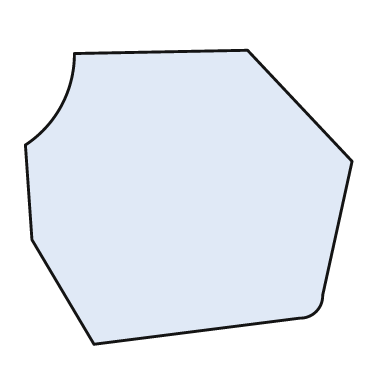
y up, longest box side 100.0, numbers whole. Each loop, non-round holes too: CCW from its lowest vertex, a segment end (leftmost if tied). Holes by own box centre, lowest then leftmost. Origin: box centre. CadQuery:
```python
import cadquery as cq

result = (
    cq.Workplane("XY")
    .moveTo(-29.0, -45.0)
    .lineTo(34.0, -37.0)
    .threePointArc((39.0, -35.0), (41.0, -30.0))
    .lineTo(50.0, 11.0)
    .lineTo(18.0, 45.0)
    .lineTo(-35.0, 44.0)
    .threePointArc((-39.0, 28.0), (-50.0, 16.0))
    .lineTo(-48.0, -13.0)
    .close()
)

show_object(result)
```